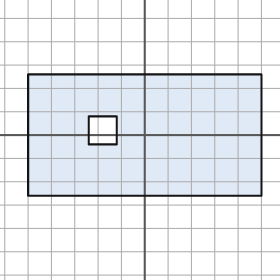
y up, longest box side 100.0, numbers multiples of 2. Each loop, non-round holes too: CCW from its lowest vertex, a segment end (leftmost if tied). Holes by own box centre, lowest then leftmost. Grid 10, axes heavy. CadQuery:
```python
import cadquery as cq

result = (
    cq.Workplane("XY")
    .moveTo(-50.0, -26.0)
    .lineTo(50.0, -26.0)
    .lineTo(50.0, 26.0)
    .lineTo(-50.0, 26.0)
    .close()
    .moveTo(-24.0, -4.0)
    .lineTo(-12.0, -4.0)
    .lineTo(-12.0, 8.0)
    .lineTo(-24.0, 8.0)
    .close()
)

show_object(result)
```